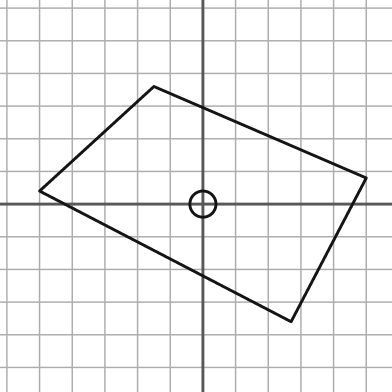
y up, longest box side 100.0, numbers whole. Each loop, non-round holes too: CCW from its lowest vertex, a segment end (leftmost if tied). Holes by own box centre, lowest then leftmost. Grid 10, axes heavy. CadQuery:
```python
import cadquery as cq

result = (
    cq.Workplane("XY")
    .moveTo(27.0, -36.0)
    .lineTo(50.0, 8.0)
    .lineTo(-15.0, 36.0)
    .lineTo(-50.0, 4.0)
    .close()
    .moveTo(0.0, 0.0)
    .circle(4.0)
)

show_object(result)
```